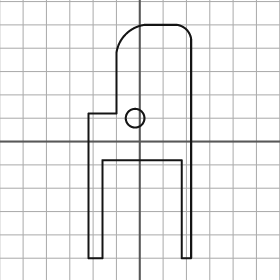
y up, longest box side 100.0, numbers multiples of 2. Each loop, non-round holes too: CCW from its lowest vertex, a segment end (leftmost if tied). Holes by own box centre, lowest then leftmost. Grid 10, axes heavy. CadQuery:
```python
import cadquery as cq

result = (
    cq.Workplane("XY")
    .moveTo(-22.0, -50.0)
    .lineTo(-16.0, -50.0)
    .lineTo(-16.0, -8.0)
    .lineTo(18.0, -8.0)
    .lineTo(18.0, -50.0)
    .lineTo(22.0, -50.0)
    .lineTo(22.0, 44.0)
    .threePointArc((20.0, 48.0), (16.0, 50.0))
    .lineTo(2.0, 50.0)
    .threePointArc((-6.0, 46.0), (-10.0, 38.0))
    .lineTo(-10.0, 12.0)
    .lineTo(-22.0, 12.0)
    .close()
    .moveTo(-2.0, 10.0)
    .circle(4.0)
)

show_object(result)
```